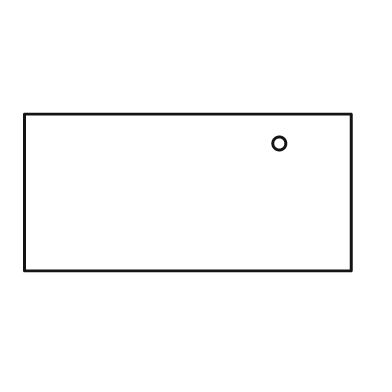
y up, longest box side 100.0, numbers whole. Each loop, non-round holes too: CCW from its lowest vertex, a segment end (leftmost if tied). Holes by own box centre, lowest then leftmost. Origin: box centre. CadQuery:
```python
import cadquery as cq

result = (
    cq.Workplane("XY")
    .moveTo(-50.0, -24.0)
    .lineTo(50.0, -24.0)
    .lineTo(50.0, 24.0)
    .lineTo(-50.0, 24.0)
    .close()
    .moveTo(28.0, 15.0)
    .circle(2.0)
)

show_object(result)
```